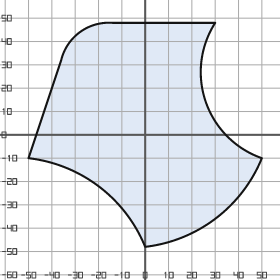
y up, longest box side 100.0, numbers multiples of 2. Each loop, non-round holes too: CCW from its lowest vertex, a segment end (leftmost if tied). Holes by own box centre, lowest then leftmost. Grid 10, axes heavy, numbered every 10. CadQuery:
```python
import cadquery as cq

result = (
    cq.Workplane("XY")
    .moveTo(0.0, -48.0)
    .threePointArc((30.0, -36.0), (50.0, -10.0))
    .threePointArc((26.0, 14.0), (30.0, 48.0))
    .lineTo(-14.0, 48.0)
    .threePointArc((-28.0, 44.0), (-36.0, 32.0))
    .lineTo(-50.0, -10.0)
    .threePointArc((-20.0, -22.0), (0.0, -48.0))
    .close()
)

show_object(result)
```